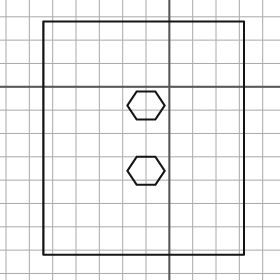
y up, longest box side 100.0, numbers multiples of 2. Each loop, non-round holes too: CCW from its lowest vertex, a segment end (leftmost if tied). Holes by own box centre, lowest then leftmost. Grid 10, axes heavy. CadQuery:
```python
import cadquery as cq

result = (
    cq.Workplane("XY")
    .moveTo(-54.0, -72.0)
    .lineTo(32.0, -72.0)
    .lineTo(32.0, 28.0)
    .lineTo(-54.0, 28.0)
    .close()
    .moveTo(-14.0, -42.0)
    .lineTo(-6.0, -42.0)
    .lineTo(-2.0, -36.0)
    .lineTo(-6.0, -30.0)
    .lineTo(-14.0, -30.0)
    .lineTo(-18.0, -36.0)
    .close()
    .moveTo(-14.0, -14.0)
    .lineTo(-6.0, -14.0)
    .lineTo(-2.0, -8.0)
    .lineTo(-6.0, -2.0)
    .lineTo(-14.0, -2.0)
    .lineTo(-18.0, -8.0)
    .close()
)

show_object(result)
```